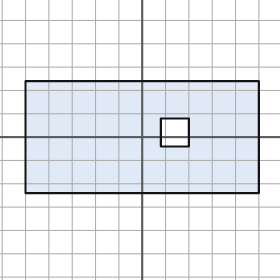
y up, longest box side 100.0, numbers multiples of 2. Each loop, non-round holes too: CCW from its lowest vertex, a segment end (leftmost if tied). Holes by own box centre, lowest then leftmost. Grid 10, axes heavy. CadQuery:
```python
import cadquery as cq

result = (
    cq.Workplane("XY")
    .moveTo(-50.0, -24.0)
    .lineTo(50.0, -24.0)
    .lineTo(50.0, 24.0)
    .lineTo(-50.0, 24.0)
    .close()
    .moveTo(8.0, -4.0)
    .lineTo(20.0, -4.0)
    .lineTo(20.0, 8.0)
    .lineTo(8.0, 8.0)
    .close()
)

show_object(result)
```